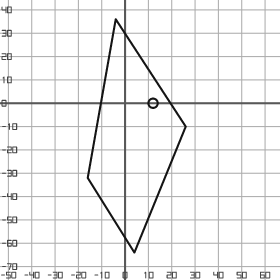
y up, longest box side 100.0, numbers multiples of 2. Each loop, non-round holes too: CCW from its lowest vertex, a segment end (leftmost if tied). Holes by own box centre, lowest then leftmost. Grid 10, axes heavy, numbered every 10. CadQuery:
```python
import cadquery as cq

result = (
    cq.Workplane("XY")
    .moveTo(4.0, -64.0)
    .lineTo(26.0, -10.0)
    .lineTo(-4.0, 36.0)
    .lineTo(-16.0, -32.0)
    .close()
    .moveTo(12.0, 0.0)
    .circle(2.0)
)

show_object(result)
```